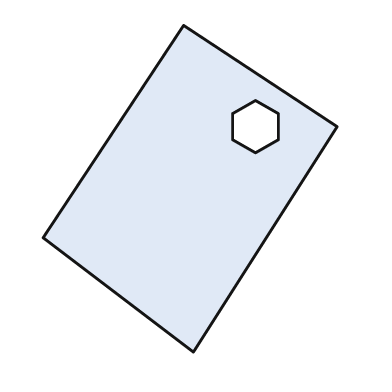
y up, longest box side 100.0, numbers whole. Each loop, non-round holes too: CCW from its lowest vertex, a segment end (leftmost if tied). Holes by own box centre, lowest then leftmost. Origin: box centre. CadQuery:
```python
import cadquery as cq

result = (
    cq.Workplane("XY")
    .moveTo(1.0, -50.0)
    .lineTo(45.0, 19.0)
    .lineTo(-2.0, 50.0)
    .lineTo(-45.0, -15.0)
    .close()
    .moveTo(20.0, 11.0)
    .lineTo(27.0, 15.0)
    .lineTo(27.0, 23.0)
    .lineTo(20.0, 27.0)
    .lineTo(13.0, 23.0)
    .lineTo(13.0, 15.0)
    .close()
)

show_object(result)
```